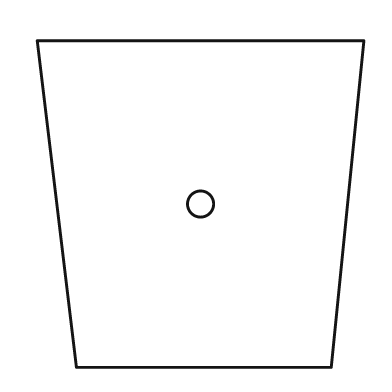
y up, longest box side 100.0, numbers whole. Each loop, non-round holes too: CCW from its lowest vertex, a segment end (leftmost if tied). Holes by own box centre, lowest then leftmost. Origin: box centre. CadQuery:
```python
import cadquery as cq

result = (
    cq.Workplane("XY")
    .moveTo(-38.0, -50.0)
    .lineTo(40.0, -50.0)
    .lineTo(50.0, 50.0)
    .lineTo(-50.0, 50.0)
    .close()
    .moveTo(0.0, 0.0)
    .circle(4.0)
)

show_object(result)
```